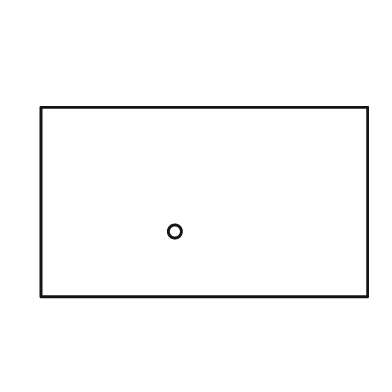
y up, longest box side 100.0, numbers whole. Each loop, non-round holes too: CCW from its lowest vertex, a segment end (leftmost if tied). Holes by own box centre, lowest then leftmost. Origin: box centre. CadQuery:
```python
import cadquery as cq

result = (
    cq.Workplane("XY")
    .moveTo(-50.0, -29.0)
    .lineTo(50.0, -29.0)
    .lineTo(50.0, 29.0)
    .lineTo(-50.0, 29.0)
    .close()
    .moveTo(-9.0, -9.0)
    .circle(2.0)
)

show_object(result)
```